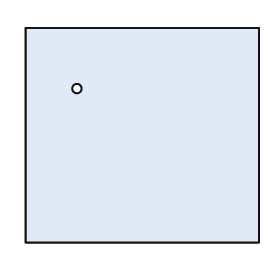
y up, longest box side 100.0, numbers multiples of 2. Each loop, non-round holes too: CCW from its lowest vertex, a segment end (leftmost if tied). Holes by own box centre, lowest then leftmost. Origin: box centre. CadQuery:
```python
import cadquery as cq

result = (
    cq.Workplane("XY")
    .moveTo(-50.0, -46.0)
    .lineTo(50.0, -46.0)
    .lineTo(50.0, 46.0)
    .lineTo(-50.0, 46.0)
    .close()
    .moveTo(-28.0, 20.0)
    .circle(2.0)
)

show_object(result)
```